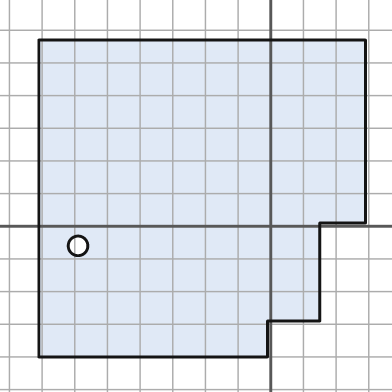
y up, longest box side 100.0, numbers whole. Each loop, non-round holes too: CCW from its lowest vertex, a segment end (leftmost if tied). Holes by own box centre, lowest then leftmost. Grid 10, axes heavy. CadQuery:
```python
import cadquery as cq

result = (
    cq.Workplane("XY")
    .moveTo(-71.0, -40.0)
    .lineTo(-1.0, -40.0)
    .lineTo(-1.0, -29.0)
    .lineTo(15.0, -29.0)
    .lineTo(15.0, 1.0)
    .lineTo(29.0, 1.0)
    .lineTo(29.0, 57.0)
    .lineTo(-71.0, 57.0)
    .close()
    .moveTo(-59.0, -6.0)
    .circle(3.0)
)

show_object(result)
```